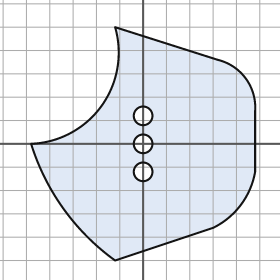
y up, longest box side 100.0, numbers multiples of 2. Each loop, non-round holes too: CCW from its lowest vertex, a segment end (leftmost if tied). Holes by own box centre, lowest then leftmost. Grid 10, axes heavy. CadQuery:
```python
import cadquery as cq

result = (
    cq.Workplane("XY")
    .moveTo(-12.0, -50.0)
    .lineTo(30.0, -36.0)
    .threePointArc((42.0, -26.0), (48.0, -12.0))
    .lineTo(48.0, 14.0)
    .threePointArc((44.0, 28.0), (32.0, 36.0))
    .lineTo(-12.0, 50.0)
    .threePointArc((-18.0, 16.0), (-48.0, 0.0))
    .threePointArc((-34.0, -28.0), (-12.0, -50.0))
    .close()
    .moveTo(0.0, -12.0)
    .circle(4.0)
    .moveTo(0.0, 0.0)
    .circle(4.0)
    .moveTo(0.0, 12.0)
    .circle(4.0)
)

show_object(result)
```